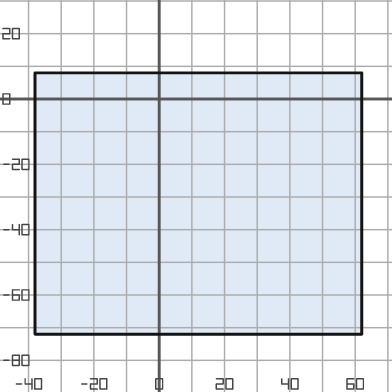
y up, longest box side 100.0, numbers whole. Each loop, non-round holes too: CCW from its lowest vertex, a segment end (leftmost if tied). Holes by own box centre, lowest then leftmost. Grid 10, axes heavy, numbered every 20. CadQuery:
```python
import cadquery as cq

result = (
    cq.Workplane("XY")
    .moveTo(-38.0, -72.0)
    .lineTo(62.0, -72.0)
    .lineTo(62.0, 8.0)
    .lineTo(-38.0, 8.0)
    .close()
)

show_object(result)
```